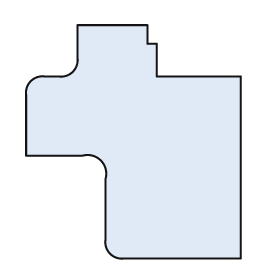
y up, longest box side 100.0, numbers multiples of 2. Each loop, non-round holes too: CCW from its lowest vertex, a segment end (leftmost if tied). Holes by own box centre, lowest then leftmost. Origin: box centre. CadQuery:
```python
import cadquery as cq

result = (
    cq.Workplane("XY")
    .moveTo(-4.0, -50.0)
    .lineTo(46.0, -50.0)
    .lineTo(46.0, 28.0)
    .lineTo(10.0, 28.0)
    .lineTo(10.0, 42.0)
    .lineTo(6.0, 42.0)
    .lineTo(6.0, 50.0)
    .lineTo(-24.0, 50.0)
    .lineTo(-24.0, 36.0)
    .threePointArc((-26.0, 30.0), (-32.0, 28.0))
    .lineTo(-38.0, 28.0)
    .threePointArc((-44.0, 26.0), (-46.0, 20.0))
    .lineTo(-46.0, -6.0)
    .lineTo(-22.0, -6.0)
    .threePointArc((-14.0, -8.0), (-12.0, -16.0))
    .lineTo(-12.0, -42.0)
    .threePointArc((-10.0, -48.0), (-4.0, -50.0))
    .close()
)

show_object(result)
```